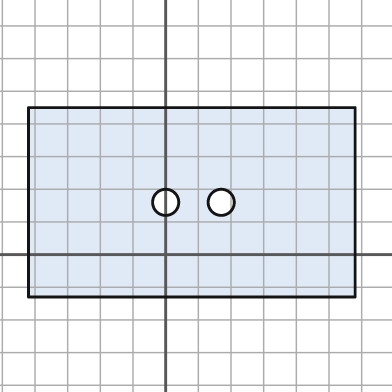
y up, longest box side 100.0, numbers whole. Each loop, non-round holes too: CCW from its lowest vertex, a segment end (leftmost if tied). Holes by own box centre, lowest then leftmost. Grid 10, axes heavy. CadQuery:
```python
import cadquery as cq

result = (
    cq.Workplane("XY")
    .moveTo(-42.0, -13.0)
    .lineTo(58.0, -13.0)
    .lineTo(58.0, 45.0)
    .lineTo(-42.0, 45.0)
    .close()
    .moveTo(0.0, 16.0)
    .circle(4.0)
    .moveTo(17.0, 16.0)
    .circle(4.0)
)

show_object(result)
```